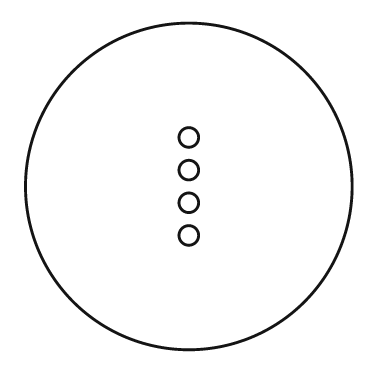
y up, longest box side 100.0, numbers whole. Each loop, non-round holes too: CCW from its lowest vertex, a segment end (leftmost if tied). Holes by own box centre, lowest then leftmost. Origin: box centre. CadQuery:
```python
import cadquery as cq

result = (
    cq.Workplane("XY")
    .moveTo(0.0, 0.0)
    .circle(50.0)
    .moveTo(0.0, -15.0)
    .circle(3.0)
    .moveTo(0.0, -5.0)
    .circle(3.0)
    .moveTo(0.0, 5.0)
    .circle(3.0)
    .moveTo(0.0, 15.0)
    .circle(3.0)
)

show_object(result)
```